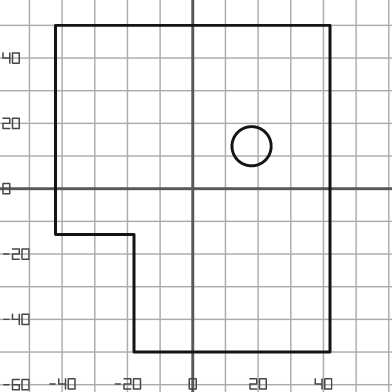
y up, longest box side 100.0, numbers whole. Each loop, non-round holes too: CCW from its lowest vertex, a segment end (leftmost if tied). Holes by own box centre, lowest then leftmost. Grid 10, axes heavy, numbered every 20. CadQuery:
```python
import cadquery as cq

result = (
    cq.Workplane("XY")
    .moveTo(-18.0, -50.0)
    .lineTo(42.0, -50.0)
    .lineTo(42.0, 50.0)
    .lineTo(-42.0, 50.0)
    .lineTo(-42.0, -14.0)
    .lineTo(-18.0, -14.0)
    .close()
    .moveTo(18.0, 13.0)
    .circle(6.0)
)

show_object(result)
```